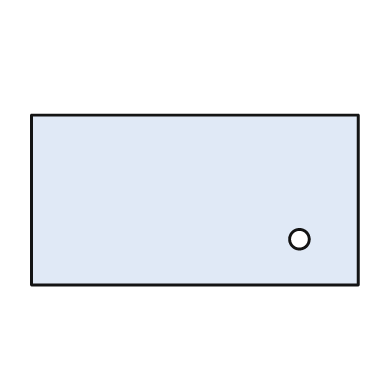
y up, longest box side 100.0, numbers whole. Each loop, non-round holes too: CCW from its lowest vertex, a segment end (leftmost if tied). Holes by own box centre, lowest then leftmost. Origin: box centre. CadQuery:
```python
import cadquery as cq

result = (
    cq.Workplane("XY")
    .moveTo(-50.0, -26.0)
    .lineTo(50.0, -26.0)
    .lineTo(50.0, 26.0)
    .lineTo(-50.0, 26.0)
    .close()
    .moveTo(32.0, -12.0)
    .circle(3.0)
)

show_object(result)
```